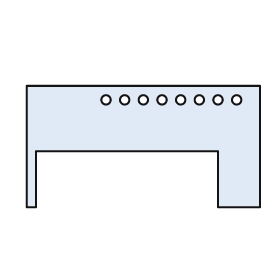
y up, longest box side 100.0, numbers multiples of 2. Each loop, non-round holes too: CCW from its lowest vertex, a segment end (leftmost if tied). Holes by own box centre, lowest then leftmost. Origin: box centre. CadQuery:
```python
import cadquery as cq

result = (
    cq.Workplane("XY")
    .moveTo(-50.0, -26.0)
    .lineTo(-46.0, -26.0)
    .lineTo(-46.0, -2.0)
    .lineTo(32.0, -2.0)
    .lineTo(32.0, -26.0)
    .lineTo(50.0, -26.0)
    .lineTo(50.0, 26.0)
    .lineTo(-50.0, 26.0)
    .close()
    .moveTo(-16.0, 20.0)
    .circle(2.0)
    .moveTo(-8.0, 20.0)
    .circle(2.0)
    .moveTo(0.0, 20.0)
    .circle(2.0)
    .moveTo(8.0, 20.0)
    .circle(2.0)
    .moveTo(16.0, 20.0)
    .circle(2.0)
    .moveTo(24.0, 20.0)
    .circle(2.0)
    .moveTo(32.0, 20.0)
    .circle(2.0)
    .moveTo(40.0, 20.0)
    .circle(2.0)
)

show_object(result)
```